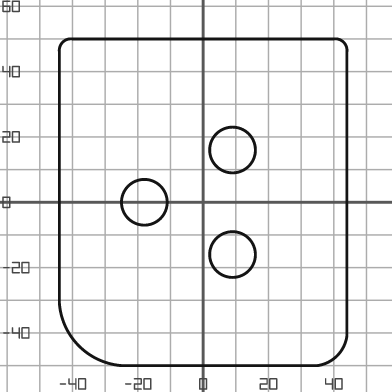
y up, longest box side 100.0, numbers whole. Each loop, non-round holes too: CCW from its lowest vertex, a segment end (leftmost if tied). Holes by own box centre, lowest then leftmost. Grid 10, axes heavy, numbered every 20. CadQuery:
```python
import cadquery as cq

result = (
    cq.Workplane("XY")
    .moveTo(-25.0, -50.0)
    .lineTo(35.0, -50.0)
    .threePointArc((41.0, -47.0), (44.0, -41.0))
    .lineTo(44.0, 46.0)
    .threePointArc((43.0, 49.0), (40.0, 50.0))
    .lineTo(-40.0, 50.0)
    .threePointArc((-43.0, 49.0), (-44.0, 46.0))
    .lineTo(-44.0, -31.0)
    .threePointArc((-38.0, -44.0), (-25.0, -50.0))
    .close()
    .moveTo(9.0, -16.0)
    .circle(7.0)
    .moveTo(-18.0, 0.0)
    .circle(7.0)
    .moveTo(9.0, 16.0)
    .circle(7.0)
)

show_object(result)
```